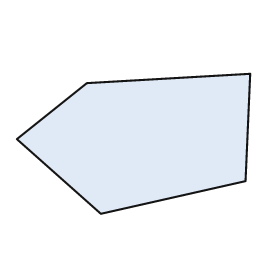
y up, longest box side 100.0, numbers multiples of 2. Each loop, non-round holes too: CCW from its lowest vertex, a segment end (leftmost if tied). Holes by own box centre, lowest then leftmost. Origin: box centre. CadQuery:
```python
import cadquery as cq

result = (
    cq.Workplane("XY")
    .moveTo(-14.0, -30.0)
    .lineTo(48.0, -16.0)
    .lineTo(50.0, 30.0)
    .lineTo(-20.0, 26.0)
    .lineTo(-50.0, 2.0)
    .close()
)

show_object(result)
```